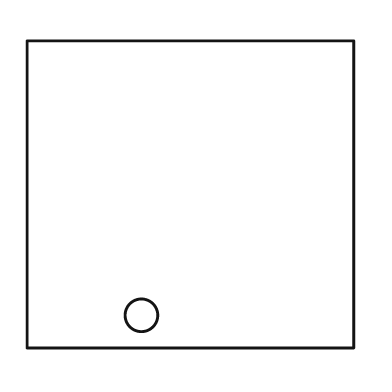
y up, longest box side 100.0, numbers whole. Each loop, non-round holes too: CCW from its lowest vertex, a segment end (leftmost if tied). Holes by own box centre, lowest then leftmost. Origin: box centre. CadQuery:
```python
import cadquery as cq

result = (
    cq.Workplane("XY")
    .moveTo(-50.0, -47.0)
    .lineTo(50.0, -47.0)
    .lineTo(50.0, 47.0)
    .lineTo(-50.0, 47.0)
    .close()
    .moveTo(-15.0, -37.0)
    .circle(5.0)
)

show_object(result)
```